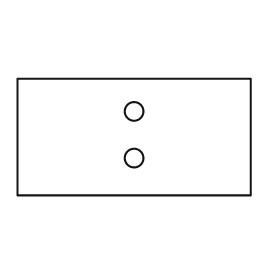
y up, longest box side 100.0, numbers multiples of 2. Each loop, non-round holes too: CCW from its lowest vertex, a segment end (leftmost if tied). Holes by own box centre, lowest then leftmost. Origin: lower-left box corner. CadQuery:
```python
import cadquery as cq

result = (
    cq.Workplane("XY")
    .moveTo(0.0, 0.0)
    .lineTo(100.0, 0.0)
    .lineTo(100.0, 50.0)
    .lineTo(0.0, 50.0)
    .close()
    .moveTo(50.0, 16.0)
    .circle(4.0)
    .moveTo(50.0, 36.0)
    .circle(4.0)
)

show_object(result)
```